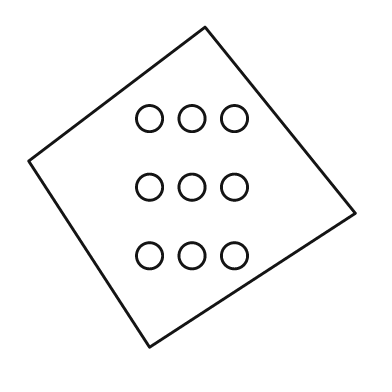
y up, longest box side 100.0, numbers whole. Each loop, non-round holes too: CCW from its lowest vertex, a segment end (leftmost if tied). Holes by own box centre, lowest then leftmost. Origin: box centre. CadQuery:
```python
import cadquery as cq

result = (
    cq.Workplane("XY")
    .moveTo(-13.0, -49.0)
    .lineTo(50.0, -8.0)
    .lineTo(4.0, 49.0)
    .lineTo(-50.0, 8.0)
    .close()
    .moveTo(-13.0, -21.0)
    .circle(4.0)
    .moveTo(0.0, -21.0)
    .circle(4.0)
    .moveTo(13.0, -21.0)
    .circle(4.0)
    .moveTo(-13.0, 0.0)
    .circle(4.0)
    .moveTo(0.0, 0.0)
    .circle(4.0)
    .moveTo(13.0, 0.0)
    .circle(4.0)
    .moveTo(-13.0, 21.0)
    .circle(4.0)
    .moveTo(0.0, 21.0)
    .circle(4.0)
    .moveTo(13.0, 21.0)
    .circle(4.0)
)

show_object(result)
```